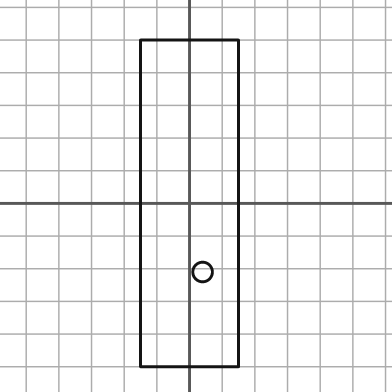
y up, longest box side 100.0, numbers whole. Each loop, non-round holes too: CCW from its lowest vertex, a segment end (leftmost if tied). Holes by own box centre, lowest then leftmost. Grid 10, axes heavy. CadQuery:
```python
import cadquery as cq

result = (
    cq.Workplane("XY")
    .moveTo(-15.0, -50.0)
    .lineTo(15.0, -50.0)
    .lineTo(15.0, 50.0)
    .lineTo(-15.0, 50.0)
    .close()
    .moveTo(4.0, -21.0)
    .circle(3.0)
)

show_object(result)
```